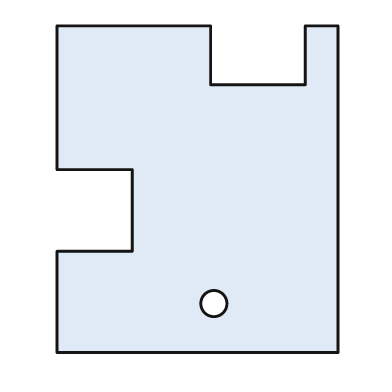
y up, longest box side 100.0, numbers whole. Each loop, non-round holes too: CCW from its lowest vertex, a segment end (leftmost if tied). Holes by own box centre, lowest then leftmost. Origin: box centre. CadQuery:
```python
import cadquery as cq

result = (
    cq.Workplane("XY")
    .moveTo(-43.0, -50.0)
    .lineTo(43.0, -50.0)
    .lineTo(43.0, 50.0)
    .lineTo(33.0, 50.0)
    .lineTo(33.0, 32.0)
    .lineTo(4.0, 32.0)
    .lineTo(4.0, 50.0)
    .lineTo(-43.0, 50.0)
    .lineTo(-43.0, 6.0)
    .lineTo(-20.0, 6.0)
    .lineTo(-20.0, -19.0)
    .lineTo(-43.0, -19.0)
    .close()
    .moveTo(5.0, -35.0)
    .circle(4.0)
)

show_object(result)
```